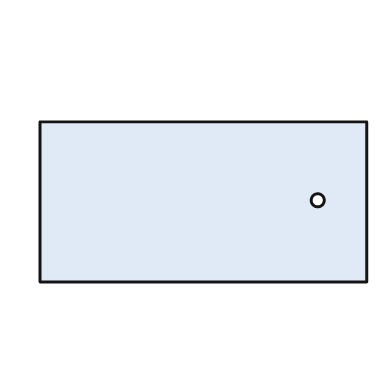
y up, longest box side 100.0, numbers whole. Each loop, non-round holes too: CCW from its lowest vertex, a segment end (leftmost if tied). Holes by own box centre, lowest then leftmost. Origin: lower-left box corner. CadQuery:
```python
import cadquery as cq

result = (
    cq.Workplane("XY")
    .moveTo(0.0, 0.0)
    .lineTo(100.0, 0.0)
    .lineTo(100.0, 49.0)
    .lineTo(0.0, 49.0)
    .close()
    .moveTo(85.0, 25.0)
    .circle(2.0)
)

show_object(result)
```